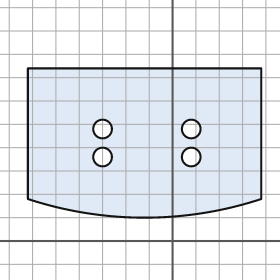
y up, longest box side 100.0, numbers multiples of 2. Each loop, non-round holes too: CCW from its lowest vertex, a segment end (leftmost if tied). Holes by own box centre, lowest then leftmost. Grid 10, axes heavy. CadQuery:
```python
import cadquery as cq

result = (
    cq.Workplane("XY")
    .moveTo(-62.0, 18.0)
    .threePointArc((-12.0, 10.0), (38.0, 18.0))
    .lineTo(38.0, 74.0)
    .lineTo(-62.0, 74.0)
    .close()
    .moveTo(-30.0, 36.0)
    .circle(4.0)
    .moveTo(8.0, 36.0)
    .circle(4.0)
    .moveTo(-30.0, 48.0)
    .circle(4.0)
    .moveTo(8.0, 48.0)
    .circle(4.0)
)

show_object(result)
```